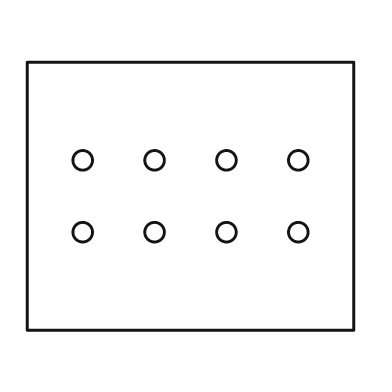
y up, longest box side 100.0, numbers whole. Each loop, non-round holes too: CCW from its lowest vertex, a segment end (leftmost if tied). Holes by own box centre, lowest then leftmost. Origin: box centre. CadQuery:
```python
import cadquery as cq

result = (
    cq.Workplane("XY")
    .moveTo(-50.0, -41.0)
    .lineTo(50.0, -41.0)
    .lineTo(50.0, 41.0)
    .lineTo(-50.0, 41.0)
    .close()
    .moveTo(-33.0, -11.0)
    .circle(3.0)
    .moveTo(-11.0, -11.0)
    .circle(3.0)
    .moveTo(11.0, -11.0)
    .circle(3.0)
    .moveTo(33.0, -11.0)
    .circle(3.0)
    .moveTo(-33.0, 11.0)
    .circle(3.0)
    .moveTo(-11.0, 11.0)
    .circle(3.0)
    .moveTo(11.0, 11.0)
    .circle(3.0)
    .moveTo(33.0, 11.0)
    .circle(3.0)
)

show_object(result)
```